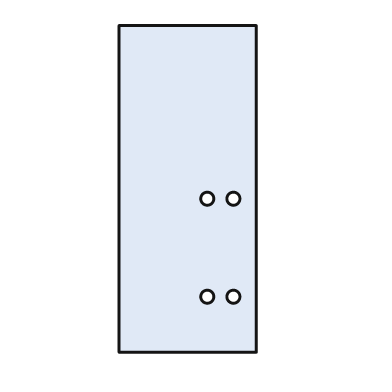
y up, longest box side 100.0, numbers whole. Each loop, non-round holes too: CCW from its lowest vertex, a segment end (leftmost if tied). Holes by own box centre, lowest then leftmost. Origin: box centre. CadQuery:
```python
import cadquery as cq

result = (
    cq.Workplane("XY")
    .moveTo(-21.0, -50.0)
    .lineTo(21.0, -50.0)
    .lineTo(21.0, 50.0)
    .lineTo(-21.0, 50.0)
    .close()
    .moveTo(6.0, -33.0)
    .circle(2.0)
    .moveTo(14.0, -33.0)
    .circle(2.0)
    .moveTo(6.0, -3.0)
    .circle(2.0)
    .moveTo(14.0, -3.0)
    .circle(2.0)
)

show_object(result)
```